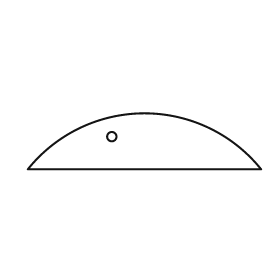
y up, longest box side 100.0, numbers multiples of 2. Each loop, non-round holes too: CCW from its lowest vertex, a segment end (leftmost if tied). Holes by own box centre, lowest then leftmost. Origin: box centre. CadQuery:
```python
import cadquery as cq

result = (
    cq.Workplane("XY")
    .moveTo(-50.0, -12.0)
    .lineTo(50.0, -12.0)
    .threePointArc((0.0, 12.0), (-50.0, -12.0))
    .close()
    .moveTo(-14.0, 2.0)
    .circle(2.0)
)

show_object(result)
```